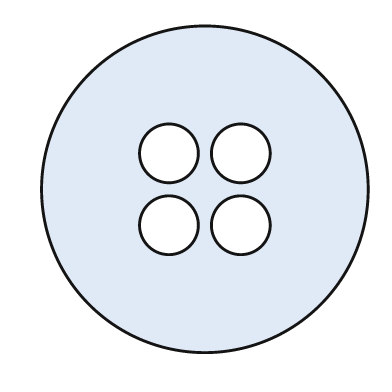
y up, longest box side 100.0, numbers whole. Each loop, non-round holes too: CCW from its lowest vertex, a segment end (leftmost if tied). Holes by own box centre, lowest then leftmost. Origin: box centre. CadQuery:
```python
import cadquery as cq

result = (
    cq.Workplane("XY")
    .moveTo(0.0, 0.0)
    .circle(50.0)
    .moveTo(-11.0, -11.0)
    .circle(9.0)
    .moveTo(11.0, -11.0)
    .circle(9.0)
    .moveTo(-11.0, 11.0)
    .circle(9.0)
    .moveTo(11.0, 11.0)
    .circle(9.0)
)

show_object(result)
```